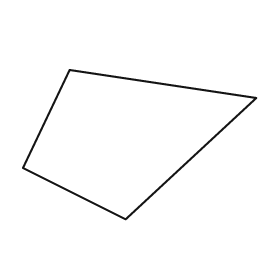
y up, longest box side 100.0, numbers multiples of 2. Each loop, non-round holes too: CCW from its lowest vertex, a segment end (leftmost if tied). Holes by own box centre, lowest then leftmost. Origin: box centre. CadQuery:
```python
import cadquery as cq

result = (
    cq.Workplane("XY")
    .moveTo(-6.0, -32.0)
    .lineTo(50.0, 20.0)
    .lineTo(-30.0, 32.0)
    .lineTo(-50.0, -10.0)
    .close()
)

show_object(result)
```